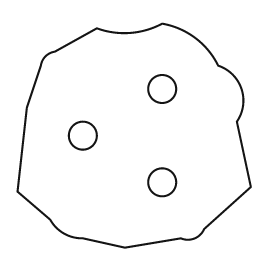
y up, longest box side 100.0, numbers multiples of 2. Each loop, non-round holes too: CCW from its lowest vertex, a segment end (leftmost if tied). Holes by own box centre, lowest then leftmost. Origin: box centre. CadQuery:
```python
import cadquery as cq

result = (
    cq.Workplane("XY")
    .moveTo(-4.0, -48.0)
    .lineTo(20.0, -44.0)
    .threePointArc((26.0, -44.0), (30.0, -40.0))
    .lineTo(50.0, -22.0)
    .lineTo(44.0, 6.0)
    .threePointArc((46.0, 20.0), (36.0, 30.0))
    .threePointArc((26.0, 42.0), (12.0, 48.0))
    .threePointArc((-2.0, 44.0), (-16.0, 46.0))
    .lineTo(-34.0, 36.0)
    .threePointArc((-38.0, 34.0), (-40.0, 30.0))
    .lineTo(-46.0, 12.0)
    .lineTo(-50.0, -24.0)
    .lineTo(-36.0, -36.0)
    .threePointArc((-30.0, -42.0), (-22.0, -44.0))
    .close()
    .moveTo(12.0, -20.0)
    .circle(6.0)
    .moveTo(-22.0, 0.0)
    .circle(6.0)
    .moveTo(12.0, 20.0)
    .circle(6.0)
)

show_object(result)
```